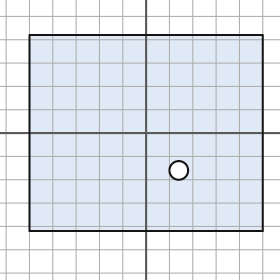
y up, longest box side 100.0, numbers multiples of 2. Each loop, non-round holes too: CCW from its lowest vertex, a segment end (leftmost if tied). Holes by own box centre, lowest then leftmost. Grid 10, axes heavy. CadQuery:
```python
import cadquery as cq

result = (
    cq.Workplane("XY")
    .moveTo(-50.0, -42.0)
    .lineTo(50.0, -42.0)
    .lineTo(50.0, 42.0)
    .lineTo(-50.0, 42.0)
    .close()
    .moveTo(14.0, -16.0)
    .circle(4.0)
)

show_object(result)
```